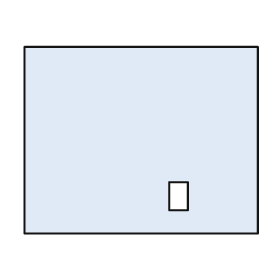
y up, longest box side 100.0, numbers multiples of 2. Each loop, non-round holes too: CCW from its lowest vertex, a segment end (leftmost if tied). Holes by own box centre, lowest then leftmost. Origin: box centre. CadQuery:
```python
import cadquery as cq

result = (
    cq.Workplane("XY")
    .moveTo(-50.0, -40.0)
    .lineTo(50.0, -40.0)
    .lineTo(50.0, 40.0)
    .lineTo(-50.0, 40.0)
    .close()
    .moveTo(12.0, -30.0)
    .lineTo(20.0, -30.0)
    .lineTo(20.0, -18.0)
    .lineTo(12.0, -18.0)
    .close()
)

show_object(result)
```